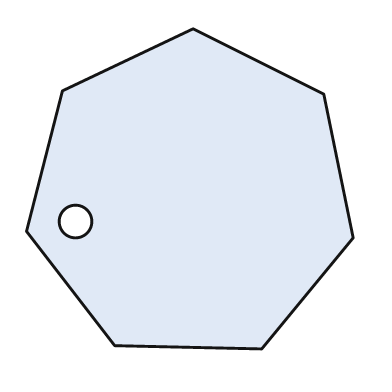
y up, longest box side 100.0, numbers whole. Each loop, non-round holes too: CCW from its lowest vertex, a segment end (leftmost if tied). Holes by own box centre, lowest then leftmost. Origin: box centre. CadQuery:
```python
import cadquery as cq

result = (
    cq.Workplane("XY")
    .moveTo(22.0, -49.0)
    .lineTo(50.0, -15.0)
    .lineTo(41.0, 29.0)
    .lineTo(1.0, 49.0)
    .lineTo(-39.0, 30.0)
    .lineTo(-50.0, -13.0)
    .lineTo(-23.0, -48.0)
    .close()
    .moveTo(-35.0, -10.0)
    .circle(5.0)
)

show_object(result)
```